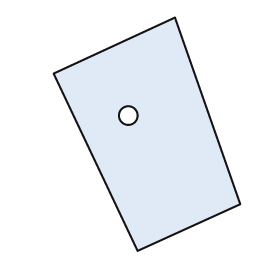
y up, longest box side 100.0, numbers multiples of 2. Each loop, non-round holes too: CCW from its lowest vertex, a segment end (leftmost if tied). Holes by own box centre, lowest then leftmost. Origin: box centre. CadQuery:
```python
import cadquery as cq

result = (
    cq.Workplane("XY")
    .moveTo(-4.0, -50.0)
    .lineTo(40.0, -30.0)
    .lineTo(12.0, 50.0)
    .lineTo(-40.0, 26.0)
    .close()
    .moveTo(-8.0, 8.0)
    .circle(4.0)
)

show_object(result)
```